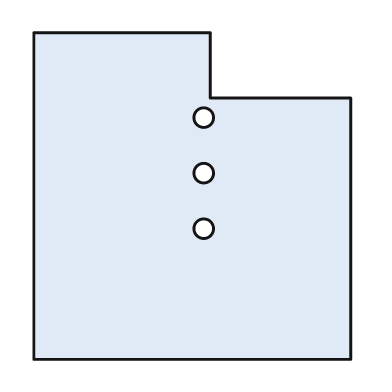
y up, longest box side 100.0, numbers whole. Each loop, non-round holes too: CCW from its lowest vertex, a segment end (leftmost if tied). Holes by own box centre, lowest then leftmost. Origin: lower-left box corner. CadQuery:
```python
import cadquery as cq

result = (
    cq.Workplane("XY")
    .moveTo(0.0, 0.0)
    .lineTo(97.0, 0.0)
    .lineTo(97.0, 80.0)
    .lineTo(54.0, 80.0)
    .lineTo(54.0, 100.0)
    .lineTo(0.0, 100.0)
    .close()
    .moveTo(52.0, 40.0)
    .circle(3.0)
    .moveTo(52.0, 57.0)
    .circle(3.0)
    .moveTo(52.0, 74.0)
    .circle(3.0)
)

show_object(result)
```